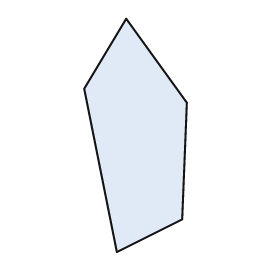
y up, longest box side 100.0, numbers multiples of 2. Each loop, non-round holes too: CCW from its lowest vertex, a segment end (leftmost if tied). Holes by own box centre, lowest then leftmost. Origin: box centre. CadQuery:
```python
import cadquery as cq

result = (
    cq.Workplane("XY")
    .moveTo(-8.0, -50.0)
    .lineTo(20.0, -36.0)
    .lineTo(22.0, 14.0)
    .lineTo(-4.0, 50.0)
    .lineTo(-22.0, 20.0)
    .close()
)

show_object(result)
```